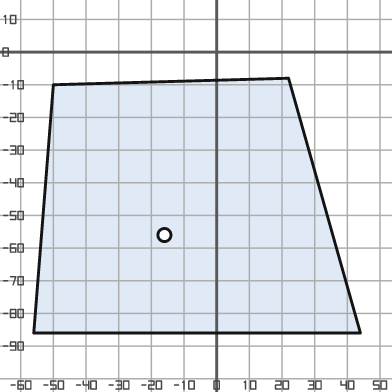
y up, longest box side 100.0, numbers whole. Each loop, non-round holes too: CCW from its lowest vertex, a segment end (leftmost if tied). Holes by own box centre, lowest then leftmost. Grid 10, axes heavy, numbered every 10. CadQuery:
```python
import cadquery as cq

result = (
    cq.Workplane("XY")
    .moveTo(-56.0, -86.0)
    .lineTo(44.0, -86.0)
    .lineTo(22.0, -8.0)
    .lineTo(-50.0, -10.0)
    .close()
    .moveTo(-16.0, -56.0)
    .circle(2.0)
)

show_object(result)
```